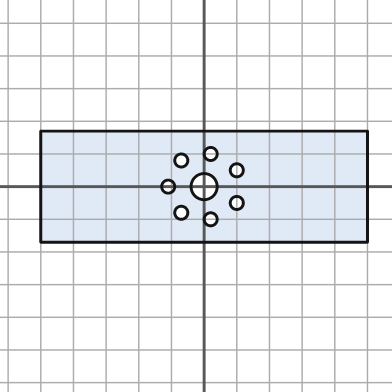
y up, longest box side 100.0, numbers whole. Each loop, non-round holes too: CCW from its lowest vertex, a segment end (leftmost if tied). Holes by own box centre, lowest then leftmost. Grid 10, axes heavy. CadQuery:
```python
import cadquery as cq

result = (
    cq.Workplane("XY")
    .moveTo(-50.0, -17.0)
    .lineTo(50.0, -17.0)
    .lineTo(50.0, 17.0)
    .lineTo(-50.0, 17.0)
    .close()
    .moveTo(2.0, -10.0)
    .circle(2.0)
    .moveTo(-7.0, -8.0)
    .circle(2.0)
    .moveTo(10.0, -5.0)
    .circle(2.0)
    .moveTo(-11.0, 0.0)
    .circle(2.0)
    .moveTo(0.0, 0.0)
    .circle(4.0)
    .moveTo(10.0, 5.0)
    .circle(2.0)
    .moveTo(-7.0, 8.0)
    .circle(2.0)
    .moveTo(2.0, 10.0)
    .circle(2.0)
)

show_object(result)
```